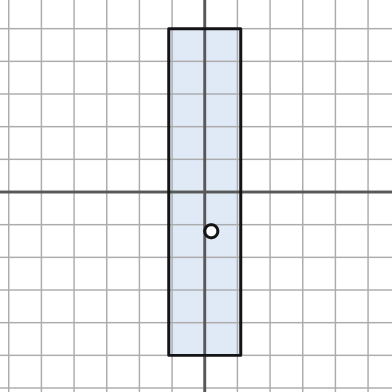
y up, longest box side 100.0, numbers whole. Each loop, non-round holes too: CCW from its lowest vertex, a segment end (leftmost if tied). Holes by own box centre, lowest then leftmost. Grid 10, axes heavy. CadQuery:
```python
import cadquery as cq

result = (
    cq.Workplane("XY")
    .moveTo(-11.0, -50.0)
    .lineTo(11.0, -50.0)
    .lineTo(11.0, 50.0)
    .lineTo(-11.0, 50.0)
    .close()
    .moveTo(2.0, -12.0)
    .circle(2.0)
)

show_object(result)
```